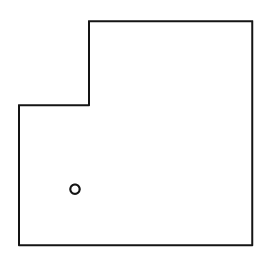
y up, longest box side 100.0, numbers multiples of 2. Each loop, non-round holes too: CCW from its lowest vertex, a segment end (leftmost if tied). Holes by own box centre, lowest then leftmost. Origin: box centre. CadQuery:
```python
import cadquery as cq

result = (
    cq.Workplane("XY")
    .moveTo(-50.0, -48.0)
    .lineTo(50.0, -48.0)
    .lineTo(50.0, 48.0)
    .lineTo(-20.0, 48.0)
    .lineTo(-20.0, 12.0)
    .lineTo(-50.0, 12.0)
    .close()
    .moveTo(-26.0, -24.0)
    .circle(2.0)
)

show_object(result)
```